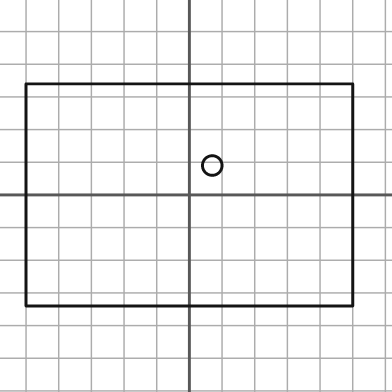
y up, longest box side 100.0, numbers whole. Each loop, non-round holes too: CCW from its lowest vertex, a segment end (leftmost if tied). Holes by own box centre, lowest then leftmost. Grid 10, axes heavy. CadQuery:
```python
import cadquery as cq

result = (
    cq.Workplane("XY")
    .moveTo(-50.0, -34.0)
    .lineTo(50.0, -34.0)
    .lineTo(50.0, 34.0)
    .lineTo(-50.0, 34.0)
    .close()
    .moveTo(7.0, 9.0)
    .circle(3.0)
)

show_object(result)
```